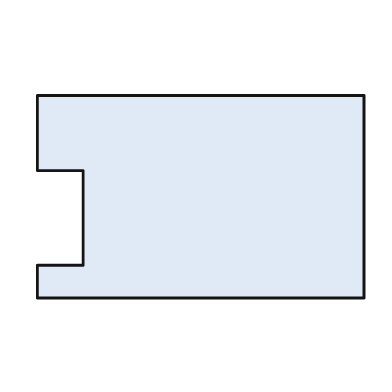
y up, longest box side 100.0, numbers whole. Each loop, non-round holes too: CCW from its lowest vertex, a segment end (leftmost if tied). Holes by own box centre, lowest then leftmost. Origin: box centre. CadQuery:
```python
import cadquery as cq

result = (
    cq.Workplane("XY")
    .moveTo(-50.0, -31.0)
    .lineTo(50.0, -31.0)
    .lineTo(50.0, 31.0)
    .lineTo(-50.0, 31.0)
    .lineTo(-50.0, 8.0)
    .lineTo(-36.0, 8.0)
    .lineTo(-36.0, -21.0)
    .lineTo(-50.0, -21.0)
    .close()
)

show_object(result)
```